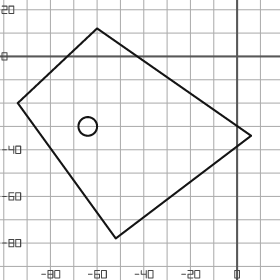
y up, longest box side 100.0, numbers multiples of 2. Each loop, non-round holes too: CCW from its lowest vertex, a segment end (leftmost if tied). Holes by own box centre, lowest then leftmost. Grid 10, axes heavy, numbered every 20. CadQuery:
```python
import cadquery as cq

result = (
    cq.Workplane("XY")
    .moveTo(-52.0, -78.0)
    .lineTo(6.0, -34.0)
    .lineTo(-60.0, 12.0)
    .lineTo(-94.0, -20.0)
    .close()
    .moveTo(-64.0, -30.0)
    .circle(4.0)
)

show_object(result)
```